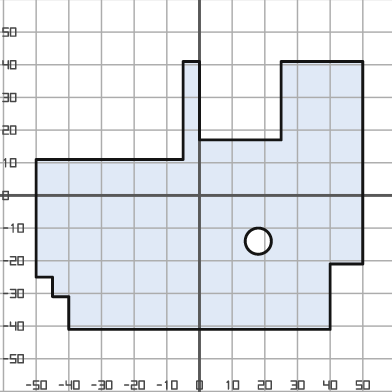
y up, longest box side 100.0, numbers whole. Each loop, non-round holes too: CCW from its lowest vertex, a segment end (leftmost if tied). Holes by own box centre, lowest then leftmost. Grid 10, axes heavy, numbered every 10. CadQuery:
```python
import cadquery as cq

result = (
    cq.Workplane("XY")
    .moveTo(-40.0, -41.0)
    .lineTo(40.0, -41.0)
    .lineTo(40.0, -21.0)
    .lineTo(50.0, -21.0)
    .lineTo(50.0, 41.0)
    .lineTo(25.0, 41.0)
    .lineTo(25.0, 17.0)
    .lineTo(0.0, 17.0)
    .lineTo(0.0, 41.0)
    .lineTo(-5.0, 41.0)
    .lineTo(-5.0, 11.0)
    .lineTo(-50.0, 11.0)
    .lineTo(-50.0, -25.0)
    .lineTo(-45.0, -25.0)
    .lineTo(-45.0, -31.0)
    .lineTo(-40.0, -31.0)
    .close()
    .moveTo(18.0, -14.0)
    .circle(4.0)
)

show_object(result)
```